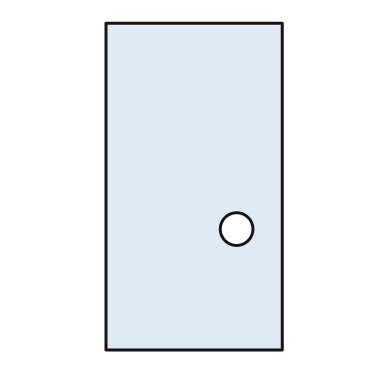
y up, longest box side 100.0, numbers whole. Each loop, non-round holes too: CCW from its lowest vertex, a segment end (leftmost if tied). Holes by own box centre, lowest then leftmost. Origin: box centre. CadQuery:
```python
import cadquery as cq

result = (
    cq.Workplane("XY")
    .moveTo(-27.0, -50.0)
    .lineTo(27.0, -50.0)
    .lineTo(27.0, 50.0)
    .lineTo(-27.0, 50.0)
    .close()
    .moveTo(13.0, -13.0)
    .circle(5.0)
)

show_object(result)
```